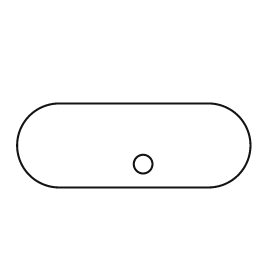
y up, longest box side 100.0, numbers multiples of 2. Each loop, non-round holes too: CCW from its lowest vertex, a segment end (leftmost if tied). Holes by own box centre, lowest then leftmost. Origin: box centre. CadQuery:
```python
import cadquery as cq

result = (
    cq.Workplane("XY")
    .moveTo(-32.0, -18.0)
    .lineTo(32.0, -18.0)
    .threePointArc((50.0, 0.0), (32.0, 18.0))
    .lineTo(-32.0, 18.0)
    .threePointArc((-50.0, 0.0), (-32.0, -18.0))
    .close()
    .moveTo(4.0, -8.0)
    .circle(4.0)
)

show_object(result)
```